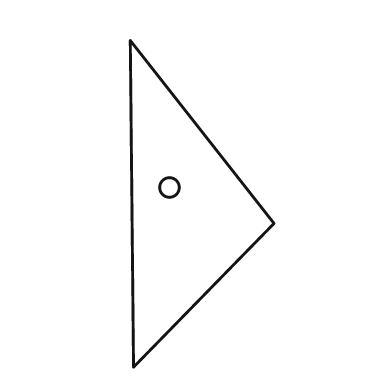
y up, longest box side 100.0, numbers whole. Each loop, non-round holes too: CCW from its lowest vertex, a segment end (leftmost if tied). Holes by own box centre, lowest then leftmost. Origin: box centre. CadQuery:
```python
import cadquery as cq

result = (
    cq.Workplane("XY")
    .moveTo(-21.0, -50.0)
    .lineTo(22.0, -6.0)
    .lineTo(-22.0, 50.0)
    .close()
    .moveTo(-10.0, 5.0)
    .circle(3.0)
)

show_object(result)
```